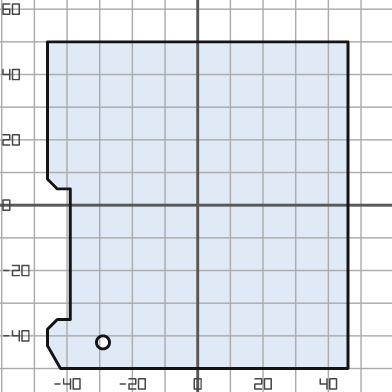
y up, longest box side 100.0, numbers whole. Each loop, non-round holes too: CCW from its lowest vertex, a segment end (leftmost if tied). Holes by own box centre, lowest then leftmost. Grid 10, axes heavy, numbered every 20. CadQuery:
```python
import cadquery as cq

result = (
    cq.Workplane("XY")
    .moveTo(-42.0, -50.0)
    .lineTo(46.0, -50.0)
    .lineTo(46.0, 50.0)
    .lineTo(-46.0, 50.0)
    .lineTo(-46.0, 8.0)
    .lineTo(-43.0, 5.0)
    .lineTo(-39.0, 5.0)
    .lineTo(-39.0, -35.0)
    .lineTo(-43.0, -35.0)
    .lineTo(-46.0, -38.0)
    .lineTo(-46.0, -43.0)
    .close()
    .moveTo(-29.0, -42.0)
    .circle(2.0)
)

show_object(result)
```